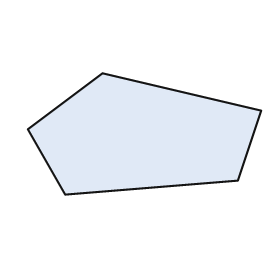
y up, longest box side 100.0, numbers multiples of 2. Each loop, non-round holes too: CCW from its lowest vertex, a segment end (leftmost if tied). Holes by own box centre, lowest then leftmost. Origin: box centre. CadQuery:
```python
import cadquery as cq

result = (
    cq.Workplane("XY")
    .moveTo(-34.0, -26.0)
    .lineTo(40.0, -20.0)
    .lineTo(50.0, 10.0)
    .lineTo(-18.0, 26.0)
    .lineTo(-50.0, 2.0)
    .close()
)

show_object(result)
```